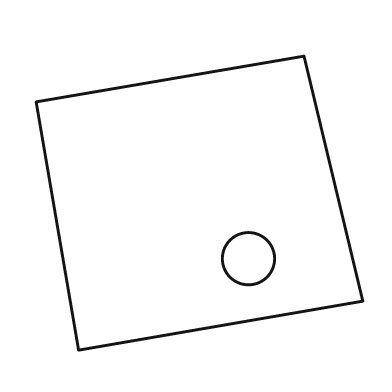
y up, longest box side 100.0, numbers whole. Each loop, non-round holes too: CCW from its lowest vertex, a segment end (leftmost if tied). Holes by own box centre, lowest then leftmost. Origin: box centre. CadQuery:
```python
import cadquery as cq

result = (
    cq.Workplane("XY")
    .moveTo(-37.0, -45.0)
    .lineTo(50.0, -30.0)
    .lineTo(32.0, 45.0)
    .lineTo(-50.0, 31.0)
    .close()
    .moveTo(15.0, -17.0)
    .circle(8.0)
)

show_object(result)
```